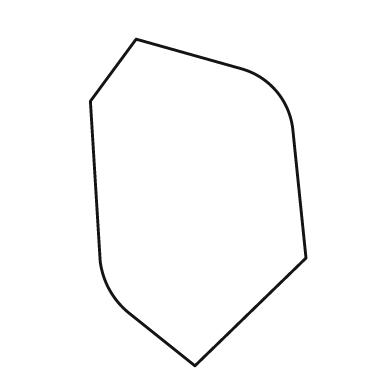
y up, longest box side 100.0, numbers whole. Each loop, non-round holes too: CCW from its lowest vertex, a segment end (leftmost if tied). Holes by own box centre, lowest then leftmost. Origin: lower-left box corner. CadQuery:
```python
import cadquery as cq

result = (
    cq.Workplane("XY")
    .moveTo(32.0, 0.0)
    .lineTo(66.0, 33.0)
    .lineTo(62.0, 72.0)
    .threePointArc((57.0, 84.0), (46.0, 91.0))
    .lineTo(14.0, 100.0)
    .lineTo(0.0, 81.0)
    .lineTo(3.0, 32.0)
    .threePointArc((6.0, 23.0), (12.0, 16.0))
    .close()
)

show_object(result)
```